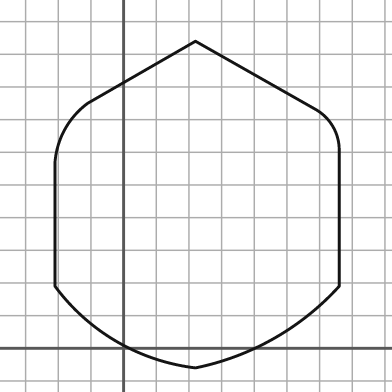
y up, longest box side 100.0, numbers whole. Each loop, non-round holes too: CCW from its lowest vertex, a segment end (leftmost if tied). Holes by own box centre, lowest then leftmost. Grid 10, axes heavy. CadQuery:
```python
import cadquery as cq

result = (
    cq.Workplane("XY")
    .moveTo(22.0, -6.0)
    .threePointArc((46.0, 3.0), (66.0, 19.0))
    .lineTo(66.0, 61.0)
    .threePointArc((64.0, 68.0), (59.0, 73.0))
    .lineTo(22.0, 94.0)
    .lineTo(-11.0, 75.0)
    .threePointArc((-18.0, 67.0), (-21.0, 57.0))
    .lineTo(-21.0, 19.0)
    .threePointArc((-2.0, 2.0), (22.0, -6.0))
    .close()
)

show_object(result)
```